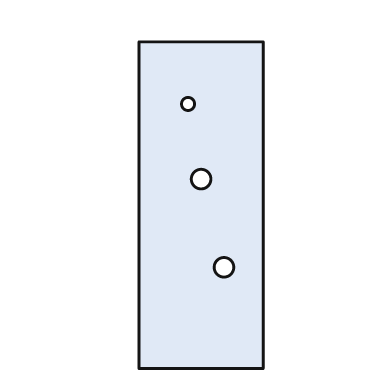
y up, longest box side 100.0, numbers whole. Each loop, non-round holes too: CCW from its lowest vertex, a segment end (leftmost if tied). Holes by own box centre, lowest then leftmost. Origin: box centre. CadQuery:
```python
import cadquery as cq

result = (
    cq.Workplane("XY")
    .moveTo(-19.0, -50.0)
    .lineTo(19.0, -50.0)
    .lineTo(19.0, 50.0)
    .lineTo(-19.0, 50.0)
    .close()
    .moveTo(7.0, -19.0)
    .circle(3.0)
    .moveTo(0.0, 8.0)
    .circle(3.0)
    .moveTo(-4.0, 31.0)
    .circle(2.0)
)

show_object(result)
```